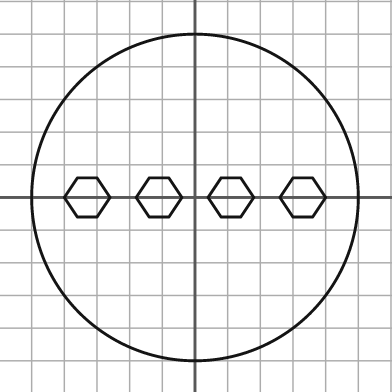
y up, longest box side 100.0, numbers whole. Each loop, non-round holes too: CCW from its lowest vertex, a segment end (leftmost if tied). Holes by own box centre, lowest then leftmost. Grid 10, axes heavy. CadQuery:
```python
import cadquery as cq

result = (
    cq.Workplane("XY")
    .moveTo(0.0, 0.0)
    .circle(50.0)
    .moveTo(-36.0, -6.0)
    .lineTo(-30.0, -6.0)
    .lineTo(-26.0, 0.0)
    .lineTo(-30.0, 6.0)
    .lineTo(-36.0, 6.0)
    .lineTo(-40.0, 0.0)
    .close()
    .moveTo(-14.0, -6.0)
    .lineTo(-8.0, -6.0)
    .lineTo(-4.0, 0.0)
    .lineTo(-8.0, 6.0)
    .lineTo(-14.0, 6.0)
    .lineTo(-18.0, 0.0)
    .close()
    .moveTo(8.0, -6.0)
    .lineTo(14.0, -6.0)
    .lineTo(18.0, 0.0)
    .lineTo(14.0, 6.0)
    .lineTo(8.0, 6.0)
    .lineTo(4.0, 0.0)
    .close()
    .moveTo(30.0, -6.0)
    .lineTo(36.0, -6.0)
    .lineTo(40.0, 0.0)
    .lineTo(36.0, 6.0)
    .lineTo(30.0, 6.0)
    .lineTo(26.0, 0.0)
    .close()
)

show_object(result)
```